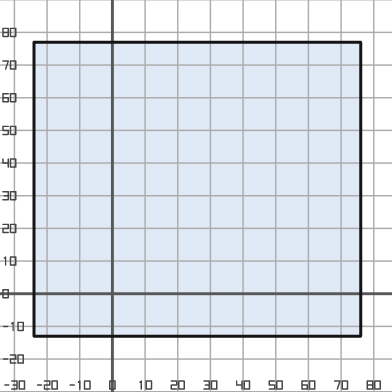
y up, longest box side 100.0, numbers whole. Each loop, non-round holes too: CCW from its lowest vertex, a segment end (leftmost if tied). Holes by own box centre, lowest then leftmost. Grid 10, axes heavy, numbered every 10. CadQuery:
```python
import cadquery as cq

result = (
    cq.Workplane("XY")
    .moveTo(-24.0, -13.0)
    .lineTo(76.0, -13.0)
    .lineTo(76.0, 77.0)
    .lineTo(-24.0, 77.0)
    .close()
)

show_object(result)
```